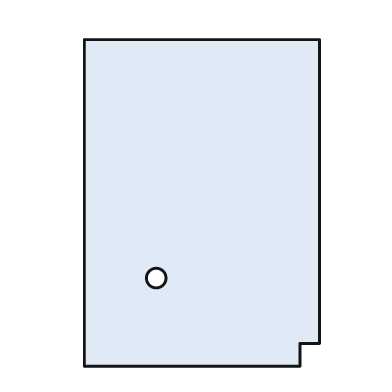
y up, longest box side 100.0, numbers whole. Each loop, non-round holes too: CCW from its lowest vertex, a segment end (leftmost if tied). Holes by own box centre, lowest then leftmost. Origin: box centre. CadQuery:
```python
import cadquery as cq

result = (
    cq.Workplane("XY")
    .moveTo(-36.0, -50.0)
    .lineTo(30.0, -50.0)
    .lineTo(30.0, -43.0)
    .lineTo(36.0, -43.0)
    .lineTo(36.0, 50.0)
    .lineTo(-36.0, 50.0)
    .close()
    .moveTo(-14.0, -23.0)
    .circle(3.0)
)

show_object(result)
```